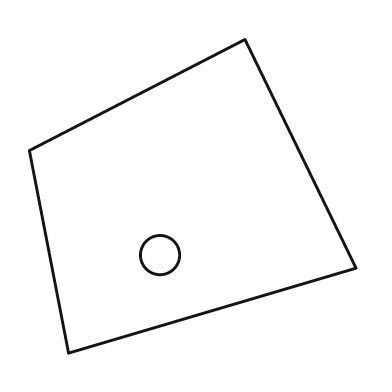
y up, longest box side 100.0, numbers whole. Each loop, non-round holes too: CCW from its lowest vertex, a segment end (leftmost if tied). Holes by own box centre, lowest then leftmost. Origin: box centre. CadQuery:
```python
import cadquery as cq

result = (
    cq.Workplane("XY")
    .moveTo(-38.0, -48.0)
    .lineTo(50.0, -22.0)
    .lineTo(16.0, 48.0)
    .lineTo(-50.0, 14.0)
    .close()
    .moveTo(-10.0, -18.0)
    .circle(6.0)
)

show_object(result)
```